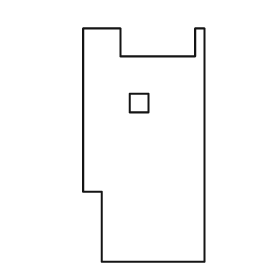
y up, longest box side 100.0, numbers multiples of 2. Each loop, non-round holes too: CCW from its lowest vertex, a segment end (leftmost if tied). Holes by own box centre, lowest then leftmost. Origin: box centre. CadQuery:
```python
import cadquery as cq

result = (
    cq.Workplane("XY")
    .moveTo(-18.0, -50.0)
    .lineTo(26.0, -50.0)
    .lineTo(26.0, 50.0)
    .lineTo(22.0, 50.0)
    .lineTo(22.0, 38.0)
    .lineTo(-10.0, 38.0)
    .lineTo(-10.0, 50.0)
    .lineTo(-26.0, 50.0)
    .lineTo(-26.0, -20.0)
    .lineTo(-18.0, -20.0)
    .close()
    .moveTo(-6.0, 14.0)
    .lineTo(2.0, 14.0)
    .lineTo(2.0, 22.0)
    .lineTo(-6.0, 22.0)
    .close()
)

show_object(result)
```